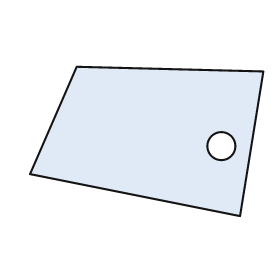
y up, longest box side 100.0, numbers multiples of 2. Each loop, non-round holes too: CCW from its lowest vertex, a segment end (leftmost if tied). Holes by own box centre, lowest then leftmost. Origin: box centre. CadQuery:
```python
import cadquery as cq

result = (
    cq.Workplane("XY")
    .moveTo(40.0, -32.0)
    .lineTo(50.0, 30.0)
    .lineTo(-30.0, 32.0)
    .lineTo(-50.0, -14.0)
    .close()
    .moveTo(32.0, -2.0)
    .circle(6.0)
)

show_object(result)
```